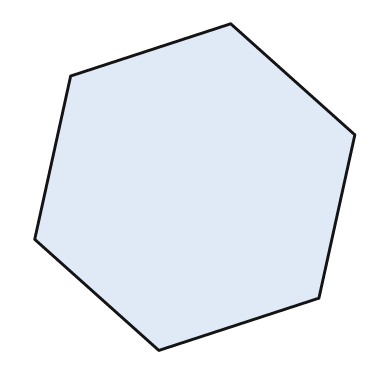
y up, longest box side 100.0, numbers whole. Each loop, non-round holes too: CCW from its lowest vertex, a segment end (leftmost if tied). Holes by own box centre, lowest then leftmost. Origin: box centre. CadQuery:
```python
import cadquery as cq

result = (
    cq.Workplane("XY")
    .moveTo(-11.0, -50.0)
    .lineTo(38.0, -34.0)
    .lineTo(49.0, 16.0)
    .lineTo(11.0, 50.0)
    .lineTo(-38.0, 34.0)
    .lineTo(-49.0, -16.0)
    .close()
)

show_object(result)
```